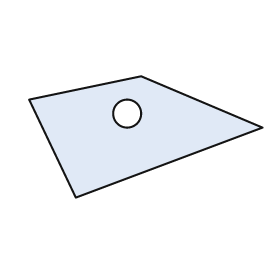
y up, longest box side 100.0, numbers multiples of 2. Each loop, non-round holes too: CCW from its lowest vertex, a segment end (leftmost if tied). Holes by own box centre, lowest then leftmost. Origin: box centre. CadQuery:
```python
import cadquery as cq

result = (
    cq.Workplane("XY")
    .moveTo(-30.0, -26.0)
    .lineTo(50.0, 4.0)
    .lineTo(-2.0, 26.0)
    .lineTo(-50.0, 16.0)
    .close()
    .moveTo(-8.0, 10.0)
    .circle(6.0)
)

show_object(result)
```